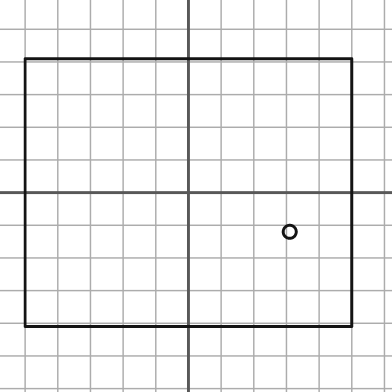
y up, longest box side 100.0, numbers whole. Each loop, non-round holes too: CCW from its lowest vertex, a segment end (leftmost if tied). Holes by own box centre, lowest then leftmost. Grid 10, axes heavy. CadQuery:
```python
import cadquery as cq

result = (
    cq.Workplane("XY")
    .moveTo(-50.0, -41.0)
    .lineTo(50.0, -41.0)
    .lineTo(50.0, 41.0)
    .lineTo(-50.0, 41.0)
    .close()
    .moveTo(31.0, -12.0)
    .circle(2.0)
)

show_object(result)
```